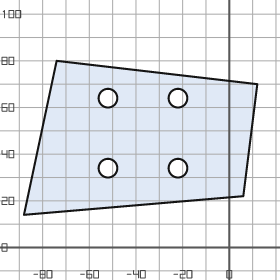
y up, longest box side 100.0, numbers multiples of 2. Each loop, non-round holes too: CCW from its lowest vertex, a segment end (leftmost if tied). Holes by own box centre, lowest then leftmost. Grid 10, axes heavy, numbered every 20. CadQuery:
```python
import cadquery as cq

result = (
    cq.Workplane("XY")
    .moveTo(-88.0, 14.0)
    .lineTo(6.0, 22.0)
    .lineTo(12.0, 70.0)
    .lineTo(-74.0, 80.0)
    .close()
    .moveTo(-52.0, 34.0)
    .circle(4.0)
    .moveTo(-22.0, 34.0)
    .circle(4.0)
    .moveTo(-52.0, 64.0)
    .circle(4.0)
    .moveTo(-22.0, 64.0)
    .circle(4.0)
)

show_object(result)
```